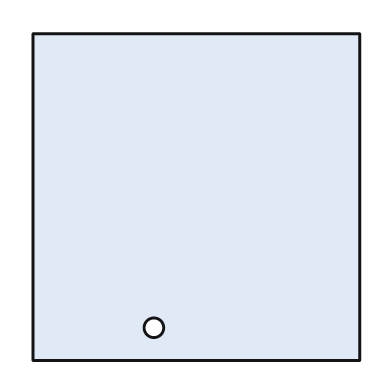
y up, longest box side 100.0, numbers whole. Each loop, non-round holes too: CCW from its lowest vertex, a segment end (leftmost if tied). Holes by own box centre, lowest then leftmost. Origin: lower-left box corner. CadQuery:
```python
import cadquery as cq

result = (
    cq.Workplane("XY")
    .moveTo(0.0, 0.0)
    .lineTo(100.0, 0.0)
    .lineTo(100.0, 100.0)
    .lineTo(0.0, 100.0)
    .close()
    .moveTo(37.0, 10.0)
    .circle(3.0)
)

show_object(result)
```